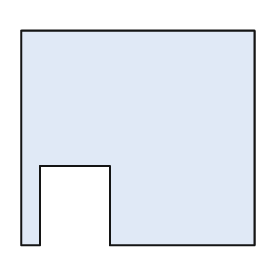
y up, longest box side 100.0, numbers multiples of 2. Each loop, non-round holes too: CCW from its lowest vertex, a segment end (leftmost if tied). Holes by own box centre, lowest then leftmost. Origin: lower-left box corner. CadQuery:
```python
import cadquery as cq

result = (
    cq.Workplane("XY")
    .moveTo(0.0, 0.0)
    .lineTo(8.0, 0.0)
    .lineTo(8.0, 34.0)
    .lineTo(38.0, 34.0)
    .lineTo(38.0, 0.0)
    .lineTo(100.0, 0.0)
    .lineTo(100.0, 92.0)
    .lineTo(0.0, 92.0)
    .close()
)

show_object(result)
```